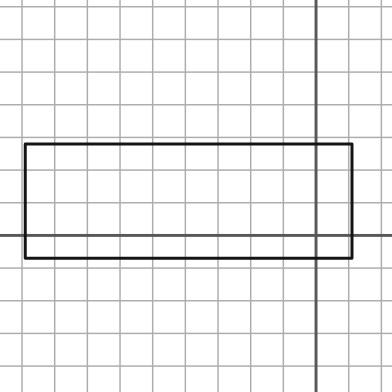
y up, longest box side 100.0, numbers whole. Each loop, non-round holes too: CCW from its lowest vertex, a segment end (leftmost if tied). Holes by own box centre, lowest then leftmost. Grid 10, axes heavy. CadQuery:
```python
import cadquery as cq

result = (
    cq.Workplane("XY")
    .moveTo(-89.0, -7.0)
    .lineTo(11.0, -7.0)
    .lineTo(11.0, 28.0)
    .lineTo(-89.0, 28.0)
    .close()
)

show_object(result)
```